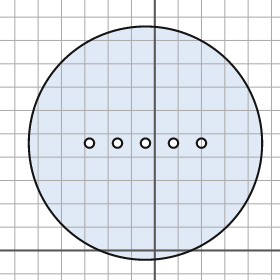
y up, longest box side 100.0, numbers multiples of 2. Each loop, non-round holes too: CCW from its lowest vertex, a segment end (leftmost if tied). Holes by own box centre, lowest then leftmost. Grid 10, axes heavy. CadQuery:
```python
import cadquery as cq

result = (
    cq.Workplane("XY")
    .moveTo(-4.0, 46.0)
    .circle(50.0)
    .moveTo(-28.0, 46.0)
    .circle(2.0)
    .moveTo(-16.0, 46.0)
    .circle(2.0)
    .moveTo(-4.0, 46.0)
    .circle(2.0)
    .moveTo(8.0, 46.0)
    .circle(2.0)
    .moveTo(20.0, 46.0)
    .circle(2.0)
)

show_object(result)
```